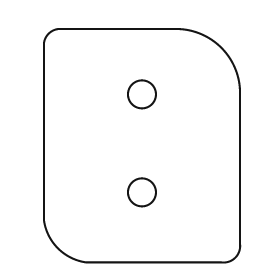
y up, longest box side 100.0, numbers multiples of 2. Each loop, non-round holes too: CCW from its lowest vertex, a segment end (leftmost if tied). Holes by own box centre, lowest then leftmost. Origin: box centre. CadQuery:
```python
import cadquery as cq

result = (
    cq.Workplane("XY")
    .moveTo(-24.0, -50.0)
    .lineTo(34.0, -50.0)
    .threePointArc((40.0, -48.0), (42.0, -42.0))
    .lineTo(42.0, 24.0)
    .threePointArc((34.0, 42.0), (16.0, 50.0))
    .lineTo(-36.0, 50.0)
    .threePointArc((-40.0, 48.0), (-42.0, 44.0))
    .lineTo(-42.0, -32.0)
    .threePointArc((-36.0, -44.0), (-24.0, -50.0))
    .close()
    .moveTo(0.0, -20.0)
    .circle(6.0)
    .moveTo(0.0, 22.0)
    .circle(6.0)
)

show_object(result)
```